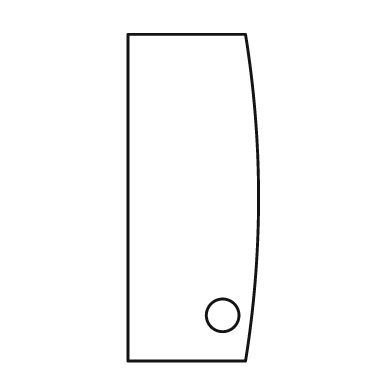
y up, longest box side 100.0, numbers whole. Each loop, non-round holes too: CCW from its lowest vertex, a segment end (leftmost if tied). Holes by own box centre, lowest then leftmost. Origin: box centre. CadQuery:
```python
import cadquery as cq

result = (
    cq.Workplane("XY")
    .moveTo(-20.0, -50.0)
    .lineTo(16.0, -50.0)
    .threePointArc((20.0, 0.0), (16.0, 50.0))
    .lineTo(-20.0, 50.0)
    .close()
    .moveTo(9.0, -36.0)
    .circle(5.0)
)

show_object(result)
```